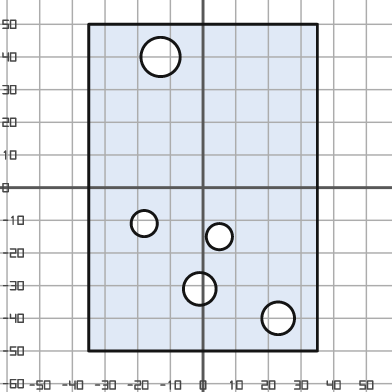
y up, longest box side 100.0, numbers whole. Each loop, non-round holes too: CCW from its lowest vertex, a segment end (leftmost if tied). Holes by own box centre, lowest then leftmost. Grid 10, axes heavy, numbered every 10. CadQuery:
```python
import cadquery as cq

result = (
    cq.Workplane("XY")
    .moveTo(-35.0, -50.0)
    .lineTo(35.0, -50.0)
    .lineTo(35.0, 50.0)
    .lineTo(-35.0, 50.0)
    .close()
    .moveTo(23.0, -40.0)
    .circle(5.0)
    .moveTo(-1.0, -31.0)
    .circle(5.0)
    .moveTo(5.0, -15.0)
    .circle(4.0)
    .moveTo(-18.0, -11.0)
    .circle(4.0)
    .moveTo(-13.0, 40.0)
    .circle(6.0)
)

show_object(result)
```